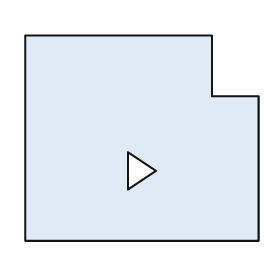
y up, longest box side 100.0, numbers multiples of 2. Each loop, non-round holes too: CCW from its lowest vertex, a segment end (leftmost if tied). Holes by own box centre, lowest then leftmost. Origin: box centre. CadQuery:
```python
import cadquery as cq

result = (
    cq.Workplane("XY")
    .moveTo(-50.0, -44.0)
    .lineTo(50.0, -44.0)
    .lineTo(50.0, 18.0)
    .lineTo(30.0, 18.0)
    .lineTo(30.0, 44.0)
    .lineTo(-50.0, 44.0)
    .close()
    .moveTo(-6.0, -22.0)
    .lineTo(6.0, -14.0)
    .lineTo(-6.0, -6.0)
    .close()
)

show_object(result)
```